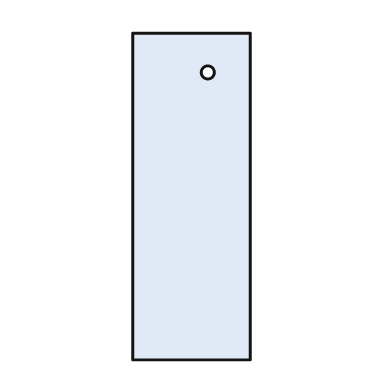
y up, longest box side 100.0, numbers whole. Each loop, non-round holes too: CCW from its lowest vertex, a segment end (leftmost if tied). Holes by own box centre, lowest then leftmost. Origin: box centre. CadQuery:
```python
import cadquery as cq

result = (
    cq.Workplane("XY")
    .moveTo(-18.0, -50.0)
    .lineTo(18.0, -50.0)
    .lineTo(18.0, 50.0)
    .lineTo(-18.0, 50.0)
    .close()
    .moveTo(5.0, 38.0)
    .circle(2.0)
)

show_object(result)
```